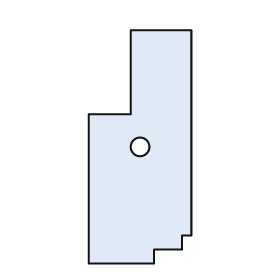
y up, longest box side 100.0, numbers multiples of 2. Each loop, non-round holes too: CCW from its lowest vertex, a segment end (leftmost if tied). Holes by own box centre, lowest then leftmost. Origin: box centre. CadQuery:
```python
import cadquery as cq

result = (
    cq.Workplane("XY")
    .moveTo(-22.0, -50.0)
    .lineTo(6.0, -50.0)
    .lineTo(6.0, -44.0)
    .lineTo(18.0, -44.0)
    .lineTo(18.0, -38.0)
    .lineTo(22.0, -38.0)
    .lineTo(22.0, 50.0)
    .lineTo(-4.0, 50.0)
    .lineTo(-4.0, 14.0)
    .lineTo(-22.0, 14.0)
    .close()
    .moveTo(0.0, 0.0)
    .circle(4.0)
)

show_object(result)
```